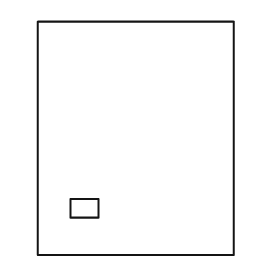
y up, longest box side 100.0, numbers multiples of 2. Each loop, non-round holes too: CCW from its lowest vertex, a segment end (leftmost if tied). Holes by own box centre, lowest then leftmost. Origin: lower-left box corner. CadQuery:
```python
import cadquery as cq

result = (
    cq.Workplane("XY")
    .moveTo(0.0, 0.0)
    .lineTo(84.0, 0.0)
    .lineTo(84.0, 100.0)
    .lineTo(0.0, 100.0)
    .close()
    .moveTo(14.0, 16.0)
    .lineTo(26.0, 16.0)
    .lineTo(26.0, 24.0)
    .lineTo(14.0, 24.0)
    .close()
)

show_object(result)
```